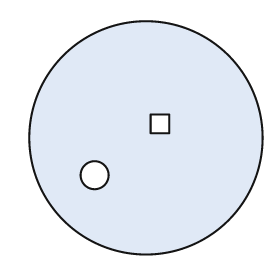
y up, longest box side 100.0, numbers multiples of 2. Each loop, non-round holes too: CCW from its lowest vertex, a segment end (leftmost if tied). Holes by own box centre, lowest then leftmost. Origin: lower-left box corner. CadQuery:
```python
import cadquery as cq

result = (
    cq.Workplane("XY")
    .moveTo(50.0, 50.0)
    .circle(50.0)
    .moveTo(28.0, 34.0)
    .circle(6.0)
    .moveTo(52.0, 52.0)
    .lineTo(60.0, 52.0)
    .lineTo(60.0, 60.0)
    .lineTo(52.0, 60.0)
    .close()
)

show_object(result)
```